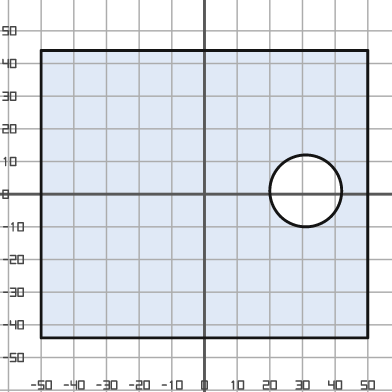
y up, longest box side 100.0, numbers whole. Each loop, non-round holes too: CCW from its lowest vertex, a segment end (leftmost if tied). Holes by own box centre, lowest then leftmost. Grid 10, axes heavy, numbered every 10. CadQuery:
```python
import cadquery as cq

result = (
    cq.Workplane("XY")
    .moveTo(-50.0, -44.0)
    .lineTo(50.0, -44.0)
    .lineTo(50.0, 44.0)
    .lineTo(-50.0, 44.0)
    .close()
    .moveTo(31.0, 1.0)
    .circle(11.0)
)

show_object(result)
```